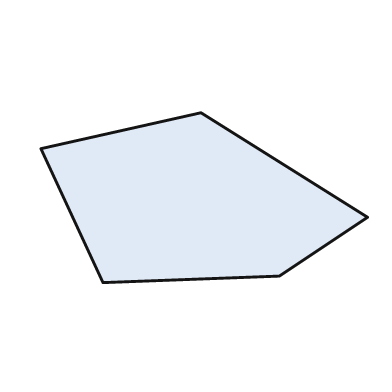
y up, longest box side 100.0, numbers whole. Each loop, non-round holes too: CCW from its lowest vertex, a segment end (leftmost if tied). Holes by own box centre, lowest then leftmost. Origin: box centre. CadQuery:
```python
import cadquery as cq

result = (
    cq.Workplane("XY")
    .moveTo(-31.0, -26.0)
    .lineTo(23.0, -24.0)
    .lineTo(50.0, -6.0)
    .lineTo(-1.0, 26.0)
    .lineTo(-50.0, 15.0)
    .close()
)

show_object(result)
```